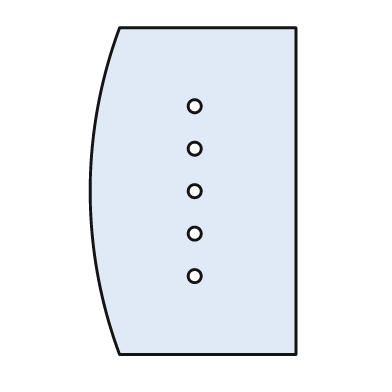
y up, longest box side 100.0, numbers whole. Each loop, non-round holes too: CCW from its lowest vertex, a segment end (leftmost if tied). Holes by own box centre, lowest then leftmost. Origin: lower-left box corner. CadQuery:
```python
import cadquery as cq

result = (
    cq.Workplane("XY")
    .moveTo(9.0, 0.0)
    .lineTo(63.0, 0.0)
    .lineTo(63.0, 100.0)
    .lineTo(9.0, 100.0)
    .threePointArc((0.0, 50.0), (9.0, 0.0))
    .close()
    .moveTo(32.0, 24.0)
    .circle(2.0)
    .moveTo(32.0, 37.0)
    .circle(2.0)
    .moveTo(32.0, 50.0)
    .circle(2.0)
    .moveTo(32.0, 63.0)
    .circle(2.0)
    .moveTo(32.0, 76.0)
    .circle(2.0)
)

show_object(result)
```